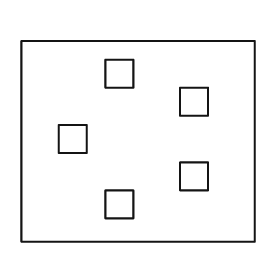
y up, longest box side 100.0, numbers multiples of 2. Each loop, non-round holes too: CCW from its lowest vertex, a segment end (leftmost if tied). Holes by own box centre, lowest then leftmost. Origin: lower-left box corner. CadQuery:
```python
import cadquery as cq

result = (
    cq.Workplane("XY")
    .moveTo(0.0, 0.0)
    .lineTo(100.0, 0.0)
    .lineTo(100.0, 86.0)
    .lineTo(0.0, 86.0)
    .close()
    .moveTo(36.0, 10.0)
    .lineTo(48.0, 10.0)
    .lineTo(48.0, 22.0)
    .lineTo(36.0, 22.0)
    .close()
    .moveTo(68.0, 22.0)
    .lineTo(80.0, 22.0)
    .lineTo(80.0, 34.0)
    .lineTo(68.0, 34.0)
    .close()
    .moveTo(16.0, 38.0)
    .lineTo(28.0, 38.0)
    .lineTo(28.0, 50.0)
    .lineTo(16.0, 50.0)
    .close()
    .moveTo(68.0, 54.0)
    .lineTo(80.0, 54.0)
    .lineTo(80.0, 66.0)
    .lineTo(68.0, 66.0)
    .close()
    .moveTo(36.0, 66.0)
    .lineTo(48.0, 66.0)
    .lineTo(48.0, 78.0)
    .lineTo(36.0, 78.0)
    .close()
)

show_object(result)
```